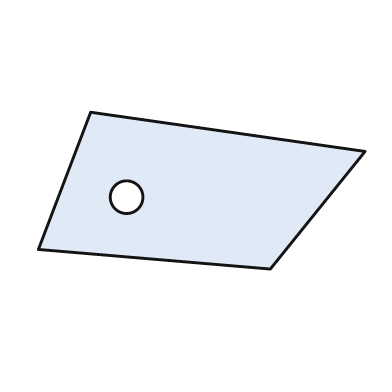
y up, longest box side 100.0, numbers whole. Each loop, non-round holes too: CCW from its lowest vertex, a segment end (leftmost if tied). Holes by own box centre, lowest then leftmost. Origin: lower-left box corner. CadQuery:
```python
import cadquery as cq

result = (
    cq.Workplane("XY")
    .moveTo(71.0, 0.0)
    .lineTo(100.0, 36.0)
    .lineTo(16.0, 48.0)
    .lineTo(0.0, 6.0)
    .close()
    .moveTo(27.0, 22.0)
    .circle(5.0)
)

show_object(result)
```